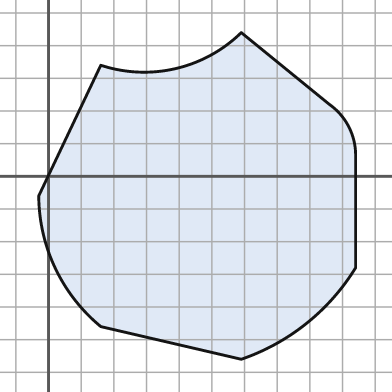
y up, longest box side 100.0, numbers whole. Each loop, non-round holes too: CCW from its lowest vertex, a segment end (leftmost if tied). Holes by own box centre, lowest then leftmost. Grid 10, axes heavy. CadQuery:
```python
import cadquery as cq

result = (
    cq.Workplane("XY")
    .moveTo(59.0, -56.0)
    .threePointArc((79.0, -45.0), (94.0, -28.0))
    .lineTo(94.0, 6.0)
    .threePointArc((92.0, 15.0), (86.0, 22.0))
    .lineTo(59.0, 44.0)
    .threePointArc((39.0, 33.0), (16.0, 34.0))
    .lineTo(-3.0, -6.0)
    .threePointArc((2.0, -28.0), (16.0, -46.0))
    .close()
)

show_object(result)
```